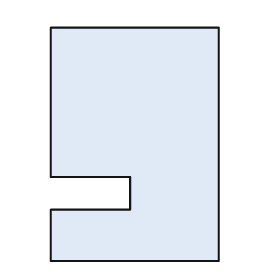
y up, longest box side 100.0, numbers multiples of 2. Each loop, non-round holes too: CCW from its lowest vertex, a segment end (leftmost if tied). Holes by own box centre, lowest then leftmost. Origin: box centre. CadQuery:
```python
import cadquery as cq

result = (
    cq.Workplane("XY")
    .moveTo(-36.0, -50.0)
    .lineTo(36.0, -50.0)
    .lineTo(36.0, 50.0)
    .lineTo(-36.0, 50.0)
    .lineTo(-36.0, -14.0)
    .lineTo(-2.0, -14.0)
    .lineTo(-2.0, -28.0)
    .lineTo(-36.0, -28.0)
    .close()
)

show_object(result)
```